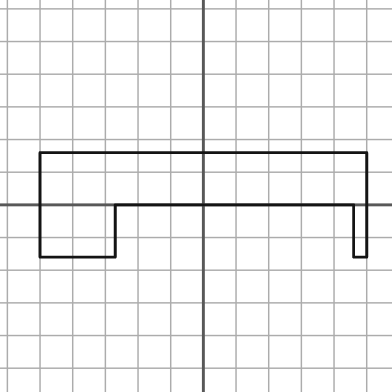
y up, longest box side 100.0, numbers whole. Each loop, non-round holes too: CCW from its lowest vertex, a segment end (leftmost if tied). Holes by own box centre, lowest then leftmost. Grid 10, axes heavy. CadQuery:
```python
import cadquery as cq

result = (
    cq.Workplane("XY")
    .moveTo(-50.0, -16.0)
    .lineTo(-27.0, -16.0)
    .lineTo(-27.0, 0.0)
    .lineTo(46.0, 0.0)
    .lineTo(46.0, -16.0)
    .lineTo(50.0, -16.0)
    .lineTo(50.0, 16.0)
    .lineTo(-50.0, 16.0)
    .close()
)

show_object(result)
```